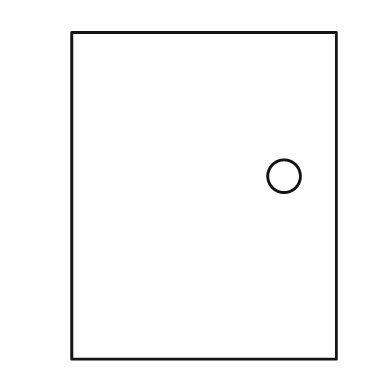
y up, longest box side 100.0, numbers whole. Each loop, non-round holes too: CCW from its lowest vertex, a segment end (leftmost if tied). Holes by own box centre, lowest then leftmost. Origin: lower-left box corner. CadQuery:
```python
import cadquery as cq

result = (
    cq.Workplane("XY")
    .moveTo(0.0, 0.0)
    .lineTo(81.0, 0.0)
    .lineTo(81.0, 100.0)
    .lineTo(0.0, 100.0)
    .close()
    .moveTo(65.0, 56.0)
    .circle(5.0)
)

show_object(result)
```